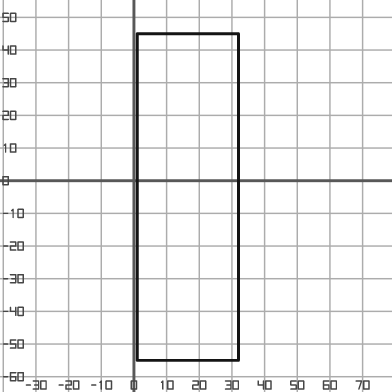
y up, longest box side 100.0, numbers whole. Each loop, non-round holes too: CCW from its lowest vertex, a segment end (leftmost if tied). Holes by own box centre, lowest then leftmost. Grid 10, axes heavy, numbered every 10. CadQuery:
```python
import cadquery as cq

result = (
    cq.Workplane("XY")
    .moveTo(1.0, -55.0)
    .lineTo(32.0, -55.0)
    .lineTo(32.0, 45.0)
    .lineTo(1.0, 45.0)
    .close()
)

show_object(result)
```